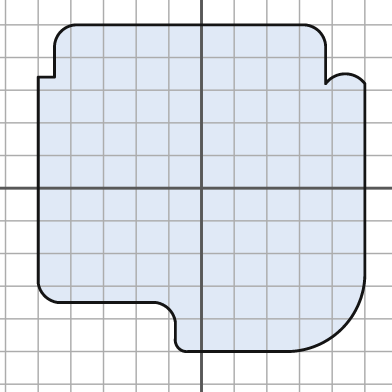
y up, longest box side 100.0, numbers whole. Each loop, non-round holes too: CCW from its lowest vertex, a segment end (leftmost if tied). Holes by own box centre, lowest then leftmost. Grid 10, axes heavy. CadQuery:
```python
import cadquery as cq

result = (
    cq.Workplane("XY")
    .moveTo(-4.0, -50.0)
    .lineTo(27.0, -50.0)
    .threePointArc((43.0, -43.0), (50.0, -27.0))
    .lineTo(50.0, 32.0)
    .threePointArc((44.0, 35.0), (38.0, 32.0))
    .lineTo(38.0, 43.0)
    .threePointArc((36.0, 48.0), (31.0, 50.0))
    .lineTo(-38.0, 50.0)
    .threePointArc((-43.0, 48.0), (-45.0, 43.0))
    .lineTo(-45.0, 34.0)
    .lineTo(-50.0, 34.0)
    .lineTo(-50.0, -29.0)
    .threePointArc((-48.0, -33.0), (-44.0, -35.0))
    .lineTo(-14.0, -35.0)
    .threePointArc((-10.0, -37.0), (-8.0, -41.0))
    .lineTo(-8.0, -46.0)
    .threePointArc((-7.0, -49.0), (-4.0, -50.0))
    .close()
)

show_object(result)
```